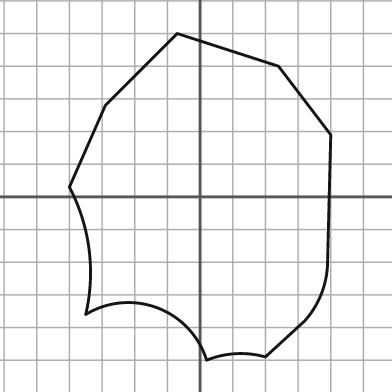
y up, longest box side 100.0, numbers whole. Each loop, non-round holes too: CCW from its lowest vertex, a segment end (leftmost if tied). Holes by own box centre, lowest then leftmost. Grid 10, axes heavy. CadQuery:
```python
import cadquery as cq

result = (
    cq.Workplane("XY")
    .moveTo(2.0, -50.0)
    .threePointArc((11.0, -48.0), (20.0, -49.0))
    .lineTo(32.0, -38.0)
    .threePointArc((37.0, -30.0), (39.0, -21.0))
    .lineTo(40.0, 19.0)
    .lineTo(24.0, 40.0)
    .lineTo(-7.0, 50.0)
    .lineTo(-29.0, 28.0)
    .lineTo(-40.0, 3.0)
    .threePointArc((-34.0, -16.0), (-35.0, -36.0))
    .threePointArc((-13.0, -34.0), (2.0, -50.0))
    .close()
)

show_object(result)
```